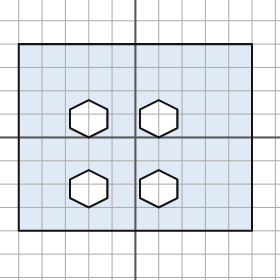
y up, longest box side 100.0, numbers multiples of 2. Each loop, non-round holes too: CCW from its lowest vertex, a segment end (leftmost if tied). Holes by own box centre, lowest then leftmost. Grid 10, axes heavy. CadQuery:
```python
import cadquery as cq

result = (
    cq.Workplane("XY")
    .moveTo(-50.0, -40.0)
    .lineTo(50.0, -40.0)
    .lineTo(50.0, 40.0)
    .lineTo(-50.0, 40.0)
    .close()
    .moveTo(-20.0, -30.0)
    .lineTo(-12.0, -26.0)
    .lineTo(-12.0, -18.0)
    .lineTo(-20.0, -14.0)
    .lineTo(-28.0, -18.0)
    .lineTo(-28.0, -26.0)
    .close()
    .moveTo(10.0, -30.0)
    .lineTo(18.0, -26.0)
    .lineTo(18.0, -18.0)
    .lineTo(10.0, -14.0)
    .lineTo(2.0, -18.0)
    .lineTo(2.0, -26.0)
    .close()
    .moveTo(-20.0, 0.0)
    .lineTo(-12.0, 4.0)
    .lineTo(-12.0, 12.0)
    .lineTo(-20.0, 16.0)
    .lineTo(-28.0, 12.0)
    .lineTo(-28.0, 4.0)
    .close()
    .moveTo(10.0, 0.0)
    .lineTo(18.0, 4.0)
    .lineTo(18.0, 12.0)
    .lineTo(10.0, 16.0)
    .lineTo(2.0, 12.0)
    .lineTo(2.0, 4.0)
    .close()
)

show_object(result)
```